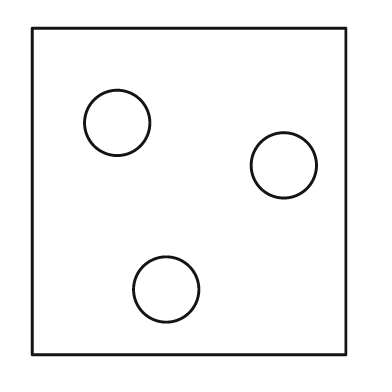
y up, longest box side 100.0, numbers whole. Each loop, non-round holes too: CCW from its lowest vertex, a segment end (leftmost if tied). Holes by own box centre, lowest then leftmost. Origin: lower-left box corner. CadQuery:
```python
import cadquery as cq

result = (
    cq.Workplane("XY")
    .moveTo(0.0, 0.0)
    .lineTo(96.0, 0.0)
    .lineTo(96.0, 100.0)
    .lineTo(0.0, 100.0)
    .close()
    .moveTo(41.0, 20.0)
    .circle(10.0)
    .moveTo(77.0, 58.0)
    .circle(10.0)
    .moveTo(26.0, 71.0)
    .circle(10.0)
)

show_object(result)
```